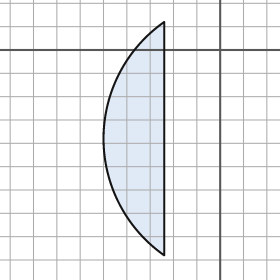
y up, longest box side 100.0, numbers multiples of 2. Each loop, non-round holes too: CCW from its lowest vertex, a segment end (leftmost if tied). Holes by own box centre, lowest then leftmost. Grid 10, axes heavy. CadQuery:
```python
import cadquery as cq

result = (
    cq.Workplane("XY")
    .moveTo(-24.0, -88.0)
    .lineTo(-24.0, 12.0)
    .threePointArc((-50.0, -38.0), (-24.0, -88.0))
    .close()
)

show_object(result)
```